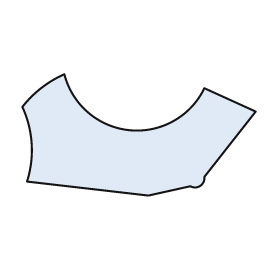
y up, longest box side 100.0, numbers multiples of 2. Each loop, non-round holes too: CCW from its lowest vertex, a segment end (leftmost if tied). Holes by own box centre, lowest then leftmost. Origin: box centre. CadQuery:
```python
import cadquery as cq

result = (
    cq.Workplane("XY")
    .moveTo(4.0, -26.0)
    .lineTo(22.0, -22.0)
    .threePointArc((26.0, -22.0), (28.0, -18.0))
    .lineTo(50.0, 10.0)
    .lineTo(28.0, 20.0)
    .threePointArc((-4.0, 2.0), (-32.0, 26.0))
    .threePointArc((-42.0, 20.0), (-50.0, 12.0))
    .threePointArc((-46.0, -4.0), (-48.0, -20.0))
    .close()
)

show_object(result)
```